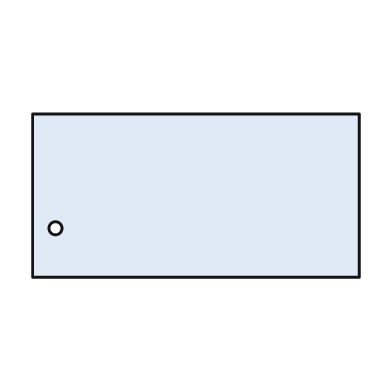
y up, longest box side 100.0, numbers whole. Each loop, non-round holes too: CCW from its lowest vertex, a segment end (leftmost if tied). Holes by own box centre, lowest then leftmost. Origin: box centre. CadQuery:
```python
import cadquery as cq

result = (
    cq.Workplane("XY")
    .moveTo(-50.0, -25.0)
    .lineTo(50.0, -25.0)
    .lineTo(50.0, 25.0)
    .lineTo(-50.0, 25.0)
    .close()
    .moveTo(-43.0, -10.0)
    .circle(2.0)
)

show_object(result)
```